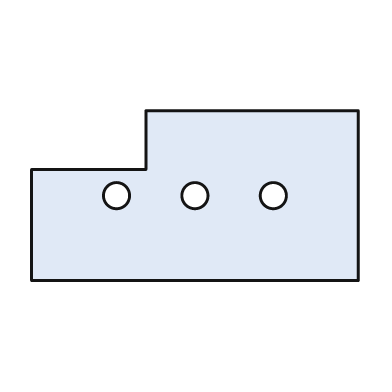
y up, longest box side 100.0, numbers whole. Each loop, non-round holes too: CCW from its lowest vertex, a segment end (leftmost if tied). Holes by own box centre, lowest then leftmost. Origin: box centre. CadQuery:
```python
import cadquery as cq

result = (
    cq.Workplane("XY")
    .moveTo(-50.0, -26.0)
    .lineTo(50.0, -26.0)
    .lineTo(50.0, 26.0)
    .lineTo(-15.0, 26.0)
    .lineTo(-15.0, 8.0)
    .lineTo(-50.0, 8.0)
    .close()
    .moveTo(-24.0, 0.0)
    .circle(4.0)
    .moveTo(0.0, 0.0)
    .circle(4.0)
    .moveTo(24.0, 0.0)
    .circle(4.0)
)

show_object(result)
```